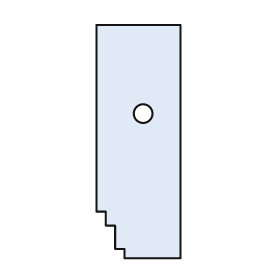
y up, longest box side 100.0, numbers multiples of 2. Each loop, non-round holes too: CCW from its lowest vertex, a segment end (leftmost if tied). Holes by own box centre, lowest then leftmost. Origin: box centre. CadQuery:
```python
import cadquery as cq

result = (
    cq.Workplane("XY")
    .moveTo(-6.0, -50.0)
    .lineTo(18.0, -50.0)
    .lineTo(18.0, 50.0)
    .lineTo(-18.0, 50.0)
    .lineTo(-18.0, -30.0)
    .lineTo(-14.0, -30.0)
    .lineTo(-14.0, -36.0)
    .lineTo(-10.0, -36.0)
    .lineTo(-10.0, -46.0)
    .lineTo(-6.0, -46.0)
    .close()
    .moveTo(2.0, 12.0)
    .circle(4.0)
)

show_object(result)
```